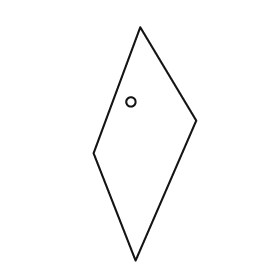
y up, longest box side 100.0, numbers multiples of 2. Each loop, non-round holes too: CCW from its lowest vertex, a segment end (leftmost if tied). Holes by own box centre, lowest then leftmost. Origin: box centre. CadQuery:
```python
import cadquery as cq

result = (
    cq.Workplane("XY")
    .moveTo(-4.0, -50.0)
    .lineTo(22.0, 10.0)
    .lineTo(-2.0, 50.0)
    .lineTo(-22.0, -4.0)
    .close()
    .moveTo(-6.0, 18.0)
    .circle(2.0)
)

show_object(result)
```